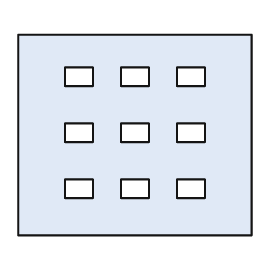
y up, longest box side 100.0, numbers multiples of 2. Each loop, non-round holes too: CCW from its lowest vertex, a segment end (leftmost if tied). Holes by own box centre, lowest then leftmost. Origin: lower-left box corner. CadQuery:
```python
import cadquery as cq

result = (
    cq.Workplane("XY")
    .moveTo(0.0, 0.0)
    .lineTo(100.0, 0.0)
    .lineTo(100.0, 86.0)
    .lineTo(0.0, 86.0)
    .close()
    .moveTo(20.0, 16.0)
    .lineTo(32.0, 16.0)
    .lineTo(32.0, 24.0)
    .lineTo(20.0, 24.0)
    .close()
    .moveTo(44.0, 16.0)
    .lineTo(56.0, 16.0)
    .lineTo(56.0, 24.0)
    .lineTo(44.0, 24.0)
    .close()
    .moveTo(68.0, 16.0)
    .lineTo(80.0, 16.0)
    .lineTo(80.0, 24.0)
    .lineTo(68.0, 24.0)
    .close()
    .moveTo(20.0, 40.0)
    .lineTo(32.0, 40.0)
    .lineTo(32.0, 48.0)
    .lineTo(20.0, 48.0)
    .close()
    .moveTo(44.0, 40.0)
    .lineTo(56.0, 40.0)
    .lineTo(56.0, 48.0)
    .lineTo(44.0, 48.0)
    .close()
    .moveTo(68.0, 40.0)
    .lineTo(80.0, 40.0)
    .lineTo(80.0, 48.0)
    .lineTo(68.0, 48.0)
    .close()
    .moveTo(20.0, 64.0)
    .lineTo(32.0, 64.0)
    .lineTo(32.0, 72.0)
    .lineTo(20.0, 72.0)
    .close()
    .moveTo(44.0, 64.0)
    .lineTo(56.0, 64.0)
    .lineTo(56.0, 72.0)
    .lineTo(44.0, 72.0)
    .close()
    .moveTo(68.0, 64.0)
    .lineTo(80.0, 64.0)
    .lineTo(80.0, 72.0)
    .lineTo(68.0, 72.0)
    .close()
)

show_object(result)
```